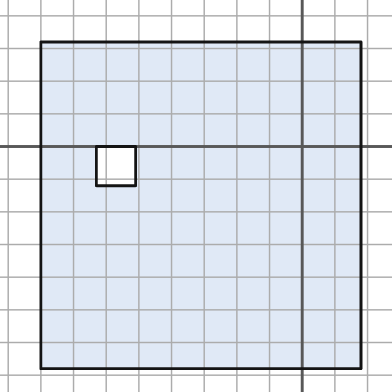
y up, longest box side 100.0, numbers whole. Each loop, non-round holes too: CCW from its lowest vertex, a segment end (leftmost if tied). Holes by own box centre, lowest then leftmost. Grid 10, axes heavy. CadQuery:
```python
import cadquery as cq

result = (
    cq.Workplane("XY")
    .moveTo(-80.0, -68.0)
    .lineTo(18.0, -68.0)
    .lineTo(18.0, 32.0)
    .lineTo(-80.0, 32.0)
    .close()
    .moveTo(-63.0, -12.0)
    .lineTo(-51.0, -12.0)
    .lineTo(-51.0, 0.0)
    .lineTo(-63.0, 0.0)
    .close()
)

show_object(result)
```